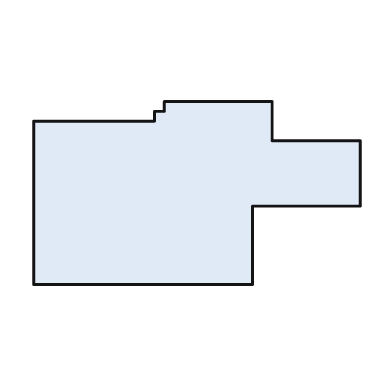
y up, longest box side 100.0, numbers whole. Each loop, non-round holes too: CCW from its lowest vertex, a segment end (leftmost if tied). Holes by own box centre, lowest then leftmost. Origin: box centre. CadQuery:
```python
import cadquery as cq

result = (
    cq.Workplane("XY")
    .moveTo(-50.0, -28.0)
    .lineTo(17.0, -28.0)
    .lineTo(17.0, -4.0)
    .lineTo(50.0, -4.0)
    .lineTo(50.0, 16.0)
    .lineTo(23.0, 16.0)
    .lineTo(23.0, 28.0)
    .lineTo(-10.0, 28.0)
    .lineTo(-10.0, 25.0)
    .lineTo(-13.0, 25.0)
    .lineTo(-13.0, 22.0)
    .lineTo(-50.0, 22.0)
    .close()
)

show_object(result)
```